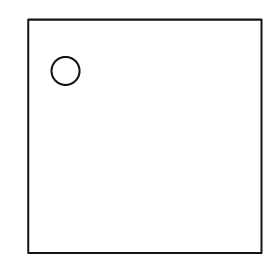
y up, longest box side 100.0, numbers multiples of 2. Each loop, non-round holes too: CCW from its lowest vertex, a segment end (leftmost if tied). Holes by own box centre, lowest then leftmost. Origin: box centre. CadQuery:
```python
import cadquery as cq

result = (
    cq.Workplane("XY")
    .moveTo(-50.0, -50.0)
    .lineTo(50.0, -50.0)
    .lineTo(50.0, 50.0)
    .lineTo(-50.0, 50.0)
    .close()
    .moveTo(-34.0, 28.0)
    .circle(6.0)
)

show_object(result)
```